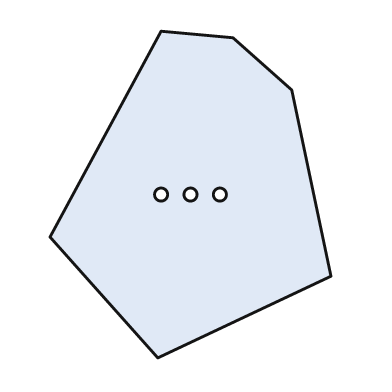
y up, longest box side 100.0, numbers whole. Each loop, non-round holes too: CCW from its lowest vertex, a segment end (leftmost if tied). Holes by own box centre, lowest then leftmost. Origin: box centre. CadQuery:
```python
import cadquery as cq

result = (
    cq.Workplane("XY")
    .moveTo(-10.0, -50.0)
    .lineTo(43.0, -25.0)
    .lineTo(31.0, 32.0)
    .lineTo(13.0, 48.0)
    .lineTo(-9.0, 50.0)
    .lineTo(-43.0, -13.0)
    .close()
    .moveTo(-9.0, 0.0)
    .circle(2.0)
    .moveTo(0.0, 0.0)
    .circle(2.0)
    .moveTo(9.0, 0.0)
    .circle(2.0)
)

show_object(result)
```